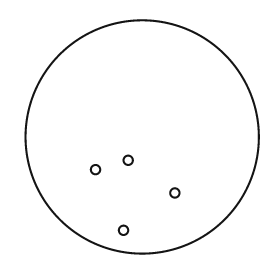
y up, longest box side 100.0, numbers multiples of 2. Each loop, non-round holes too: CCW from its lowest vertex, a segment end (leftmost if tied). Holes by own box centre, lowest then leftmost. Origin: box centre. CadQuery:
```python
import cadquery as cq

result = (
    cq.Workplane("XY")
    .moveTo(0.0, 0.0)
    .circle(50.0)
    .moveTo(-8.0, -40.0)
    .circle(2.0)
    .moveTo(14.0, -24.0)
    .circle(2.0)
    .moveTo(-20.0, -14.0)
    .circle(2.0)
    .moveTo(-6.0, -10.0)
    .circle(2.0)
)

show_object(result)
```